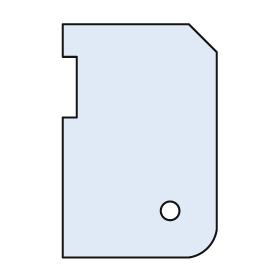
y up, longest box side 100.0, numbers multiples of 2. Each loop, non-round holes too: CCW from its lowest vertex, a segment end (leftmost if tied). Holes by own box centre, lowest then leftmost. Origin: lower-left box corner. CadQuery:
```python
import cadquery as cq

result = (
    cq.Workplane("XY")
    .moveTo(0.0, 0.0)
    .lineTo(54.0, 0.0)
    .threePointArc((62.0, 4.0), (66.0, 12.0))
    .lineTo(66.0, 88.0)
    .lineTo(54.0, 100.0)
    .lineTo(0.0, 100.0)
    .lineTo(0.0, 86.0)
    .lineTo(6.0, 86.0)
    .lineTo(6.0, 60.0)
    .lineTo(0.0, 60.0)
    .close()
    .moveTo(46.0, 20.0)
    .circle(4.0)
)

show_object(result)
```